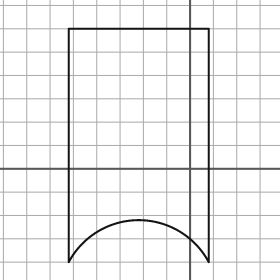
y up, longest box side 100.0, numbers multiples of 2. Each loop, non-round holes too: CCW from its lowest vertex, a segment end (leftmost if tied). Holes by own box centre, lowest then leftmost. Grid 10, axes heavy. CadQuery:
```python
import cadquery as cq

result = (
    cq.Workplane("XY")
    .moveTo(-52.0, -40.0)
    .threePointArc((-22.0, -22.0), (8.0, -40.0))
    .lineTo(8.0, 60.0)
    .lineTo(-52.0, 60.0)
    .close()
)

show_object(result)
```